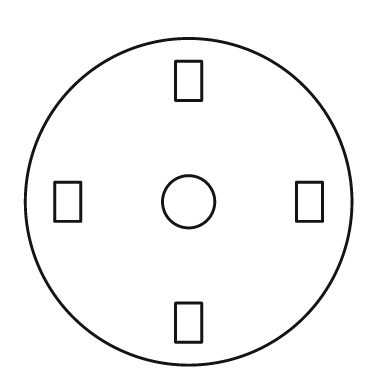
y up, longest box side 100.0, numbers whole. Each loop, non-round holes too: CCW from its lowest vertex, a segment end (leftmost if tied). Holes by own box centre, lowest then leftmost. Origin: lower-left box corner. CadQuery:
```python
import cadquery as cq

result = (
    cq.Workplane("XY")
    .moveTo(50.0, 50.0)
    .circle(50.0)
    .moveTo(46.0, 7.0)
    .lineTo(54.0, 7.0)
    .lineTo(54.0, 19.0)
    .lineTo(46.0, 19.0)
    .close()
    .moveTo(9.0, 44.0)
    .lineTo(17.0, 44.0)
    .lineTo(17.0, 56.0)
    .lineTo(9.0, 56.0)
    .close()
    .moveTo(50.0, 50.0)
    .circle(8.0)
    .moveTo(83.0, 44.0)
    .lineTo(91.0, 44.0)
    .lineTo(91.0, 56.0)
    .lineTo(83.0, 56.0)
    .close()
    .moveTo(46.0, 81.0)
    .lineTo(54.0, 81.0)
    .lineTo(54.0, 93.0)
    .lineTo(46.0, 93.0)
    .close()
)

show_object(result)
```